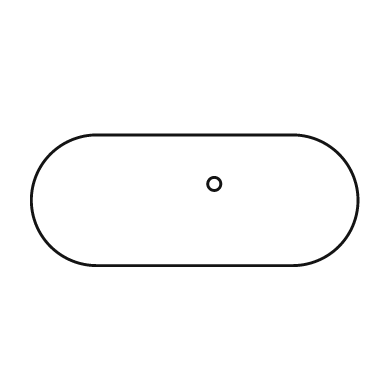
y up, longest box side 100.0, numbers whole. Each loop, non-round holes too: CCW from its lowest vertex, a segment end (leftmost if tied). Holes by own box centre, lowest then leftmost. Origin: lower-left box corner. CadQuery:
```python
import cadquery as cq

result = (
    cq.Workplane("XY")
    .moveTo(20.0, 0.0)
    .lineTo(80.0, 0.0)
    .threePointArc((100.0, 20.0), (80.0, 40.0))
    .lineTo(20.0, 40.0)
    .threePointArc((0.0, 20.0), (20.0, 0.0))
    .close()
    .moveTo(56.0, 25.0)
    .circle(2.0)
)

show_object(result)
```